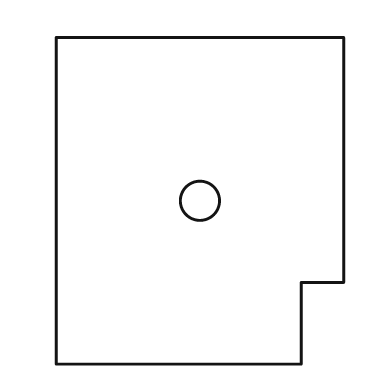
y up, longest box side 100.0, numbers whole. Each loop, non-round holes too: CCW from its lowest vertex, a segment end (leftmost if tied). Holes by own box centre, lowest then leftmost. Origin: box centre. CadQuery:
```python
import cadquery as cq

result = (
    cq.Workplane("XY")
    .moveTo(-44.0, -50.0)
    .lineTo(31.0, -50.0)
    .lineTo(31.0, -25.0)
    .lineTo(44.0, -25.0)
    .lineTo(44.0, 50.0)
    .lineTo(-44.0, 50.0)
    .close()
    .moveTo(0.0, 0.0)
    .circle(6.0)
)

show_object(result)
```